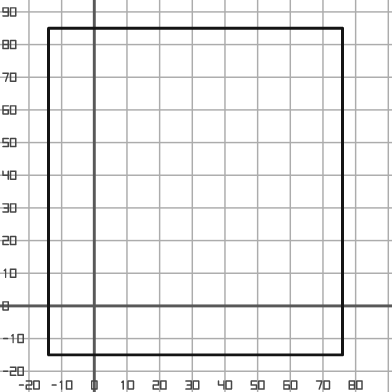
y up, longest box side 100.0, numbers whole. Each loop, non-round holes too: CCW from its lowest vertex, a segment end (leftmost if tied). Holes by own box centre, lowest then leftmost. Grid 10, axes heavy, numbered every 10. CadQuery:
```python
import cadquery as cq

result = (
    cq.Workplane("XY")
    .moveTo(-14.0, -15.0)
    .lineTo(76.0, -15.0)
    .lineTo(76.0, 85.0)
    .lineTo(-14.0, 85.0)
    .close()
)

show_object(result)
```